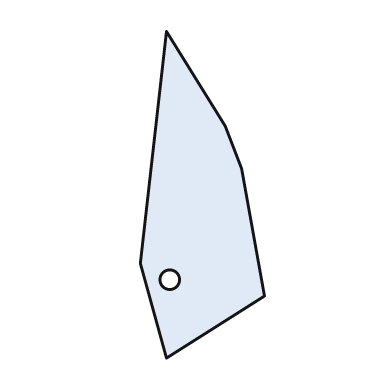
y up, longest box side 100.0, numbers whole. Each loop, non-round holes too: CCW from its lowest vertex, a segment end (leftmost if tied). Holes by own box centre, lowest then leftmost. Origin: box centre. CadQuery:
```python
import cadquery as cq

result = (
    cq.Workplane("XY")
    .moveTo(-11.0, -50.0)
    .lineTo(19.0, -31.0)
    .lineTo(12.0, 8.0)
    .lineTo(7.0, 21.0)
    .lineTo(-11.0, 50.0)
    .lineTo(-19.0, -21.0)
    .close()
    .moveTo(-10.0, -26.0)
    .circle(3.0)
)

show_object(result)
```